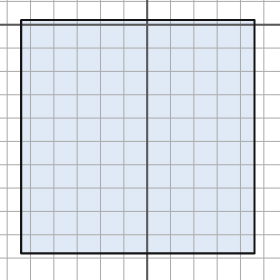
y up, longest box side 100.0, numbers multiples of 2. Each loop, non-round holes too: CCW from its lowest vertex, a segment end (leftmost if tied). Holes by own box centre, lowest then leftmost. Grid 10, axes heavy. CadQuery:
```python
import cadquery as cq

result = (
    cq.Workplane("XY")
    .moveTo(-54.0, -98.0)
    .lineTo(46.0, -98.0)
    .lineTo(46.0, 2.0)
    .lineTo(-54.0, 2.0)
    .close()
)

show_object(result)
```